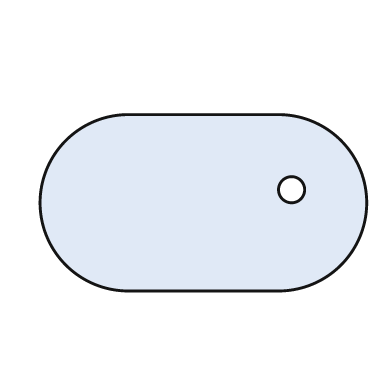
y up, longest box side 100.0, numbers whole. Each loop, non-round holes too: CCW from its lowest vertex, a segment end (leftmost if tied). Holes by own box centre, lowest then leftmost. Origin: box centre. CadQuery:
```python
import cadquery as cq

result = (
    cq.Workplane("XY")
    .moveTo(-23.0, -27.0)
    .lineTo(23.0, -27.0)
    .threePointArc((50.0, 0.0), (23.0, 27.0))
    .lineTo(-23.0, 27.0)
    .threePointArc((-50.0, 0.0), (-23.0, -27.0))
    .close()
    .moveTo(27.0, 4.0)
    .circle(4.0)
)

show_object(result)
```